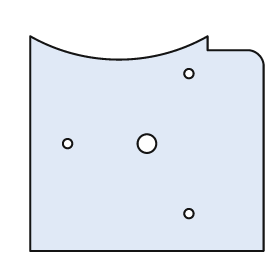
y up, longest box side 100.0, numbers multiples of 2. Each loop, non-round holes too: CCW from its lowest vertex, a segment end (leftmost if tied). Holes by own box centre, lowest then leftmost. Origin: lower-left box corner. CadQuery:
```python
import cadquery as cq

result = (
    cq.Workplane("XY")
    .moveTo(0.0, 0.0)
    .lineTo(100.0, 0.0)
    .lineTo(100.0, 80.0)
    .threePointArc((98.0, 84.0), (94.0, 86.0))
    .lineTo(76.0, 86.0)
    .lineTo(76.0, 92.0)
    .threePointArc((38.0, 82.0), (0.0, 92.0))
    .close()
    .moveTo(68.0, 16.0)
    .circle(2.0)
    .moveTo(16.0, 46.0)
    .circle(2.0)
    .moveTo(50.0, 46.0)
    .circle(4.0)
    .moveTo(68.0, 76.0)
    .circle(2.0)
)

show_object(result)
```